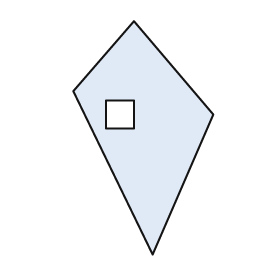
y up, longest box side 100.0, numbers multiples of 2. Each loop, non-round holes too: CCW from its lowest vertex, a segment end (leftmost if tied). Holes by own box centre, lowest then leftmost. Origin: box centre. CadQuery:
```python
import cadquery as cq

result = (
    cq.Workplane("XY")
    .moveTo(4.0, -50.0)
    .lineTo(30.0, 10.0)
    .lineTo(-4.0, 50.0)
    .lineTo(-30.0, 20.0)
    .close()
    .moveTo(-16.0, 4.0)
    .lineTo(-4.0, 4.0)
    .lineTo(-4.0, 16.0)
    .lineTo(-16.0, 16.0)
    .close()
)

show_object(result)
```